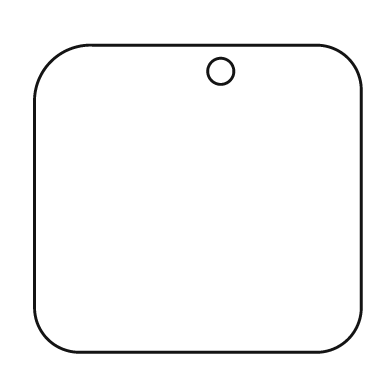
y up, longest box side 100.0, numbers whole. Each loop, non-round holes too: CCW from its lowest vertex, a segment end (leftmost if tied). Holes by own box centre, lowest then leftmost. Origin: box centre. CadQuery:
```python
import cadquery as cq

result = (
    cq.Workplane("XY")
    .moveTo(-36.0, -47.0)
    .lineTo(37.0, -47.0)
    .threePointArc((46.0, -43.0), (50.0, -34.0))
    .lineTo(50.0, 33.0)
    .threePointArc((46.0, 43.0), (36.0, 47.0))
    .lineTo(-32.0, 47.0)
    .threePointArc((-45.0, 42.0), (-50.0, 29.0))
    .lineTo(-50.0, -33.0)
    .threePointArc((-46.0, -43.0), (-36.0, -47.0))
    .close()
    .moveTo(7.0, 39.0)
    .circle(4.0)
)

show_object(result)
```